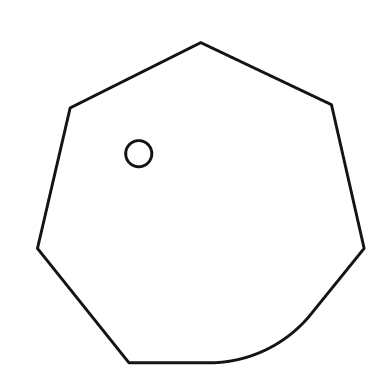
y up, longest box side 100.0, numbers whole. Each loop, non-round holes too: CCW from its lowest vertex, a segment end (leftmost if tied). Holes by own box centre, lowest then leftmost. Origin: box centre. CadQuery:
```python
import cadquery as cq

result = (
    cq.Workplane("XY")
    .moveTo(-22.0, -49.0)
    .lineTo(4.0, -49.0)
    .threePointArc((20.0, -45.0), (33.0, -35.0))
    .lineTo(50.0, -14.0)
    .lineTo(40.0, 30.0)
    .lineTo(0.0, 49.0)
    .lineTo(-40.0, 29.0)
    .lineTo(-50.0, -14.0)
    .close()
    .moveTo(-19.0, 15.0)
    .circle(4.0)
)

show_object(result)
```